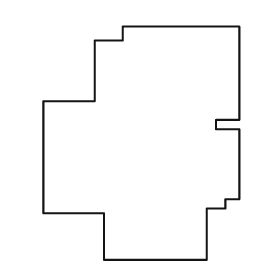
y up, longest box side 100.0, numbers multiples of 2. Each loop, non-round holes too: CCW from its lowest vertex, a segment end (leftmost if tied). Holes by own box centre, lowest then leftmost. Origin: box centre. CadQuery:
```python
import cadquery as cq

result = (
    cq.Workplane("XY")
    .moveTo(-16.0, -50.0)
    .lineTo(28.0, -50.0)
    .lineTo(28.0, -28.0)
    .lineTo(36.0, -28.0)
    .lineTo(36.0, -24.0)
    .lineTo(42.0, -24.0)
    .lineTo(42.0, 6.0)
    .lineTo(32.0, 6.0)
    .lineTo(32.0, 10.0)
    .lineTo(42.0, 10.0)
    .lineTo(42.0, 50.0)
    .lineTo(-8.0, 50.0)
    .lineTo(-8.0, 44.0)
    .lineTo(-20.0, 44.0)
    .lineTo(-20.0, 18.0)
    .lineTo(-42.0, 18.0)
    .lineTo(-42.0, -30.0)
    .lineTo(-16.0, -30.0)
    .close()
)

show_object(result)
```